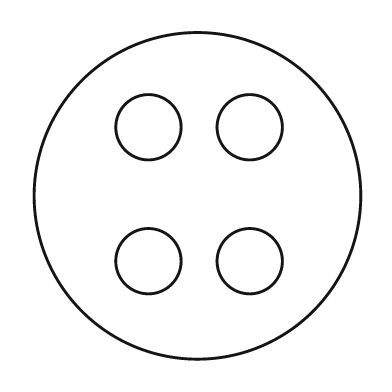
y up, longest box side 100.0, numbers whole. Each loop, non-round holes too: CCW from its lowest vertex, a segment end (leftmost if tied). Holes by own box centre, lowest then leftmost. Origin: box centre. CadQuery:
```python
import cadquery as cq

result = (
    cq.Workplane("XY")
    .moveTo(0.0, 0.0)
    .circle(50.0)
    .moveTo(-15.0, -20.0)
    .circle(10.0)
    .moveTo(16.0, -20.0)
    .circle(10.0)
    .moveTo(-15.0, 21.0)
    .circle(10.0)
    .moveTo(16.0, 21.0)
    .circle(10.0)
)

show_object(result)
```